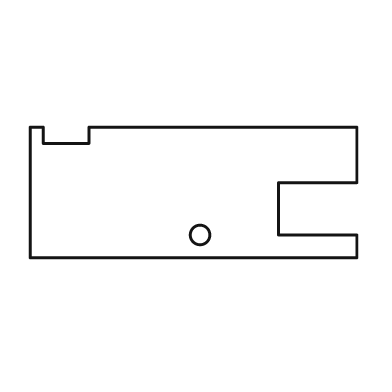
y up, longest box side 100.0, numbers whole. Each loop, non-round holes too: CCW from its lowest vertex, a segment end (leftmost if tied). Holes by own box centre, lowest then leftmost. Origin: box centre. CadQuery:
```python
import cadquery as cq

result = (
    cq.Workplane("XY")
    .moveTo(-50.0, -20.0)
    .lineTo(50.0, -20.0)
    .lineTo(50.0, -13.0)
    .lineTo(26.0, -13.0)
    .lineTo(26.0, 3.0)
    .lineTo(50.0, 3.0)
    .lineTo(50.0, 20.0)
    .lineTo(-32.0, 20.0)
    .lineTo(-32.0, 15.0)
    .lineTo(-46.0, 15.0)
    .lineTo(-46.0, 20.0)
    .lineTo(-50.0, 20.0)
    .close()
    .moveTo(2.0, -13.0)
    .circle(3.0)
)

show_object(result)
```